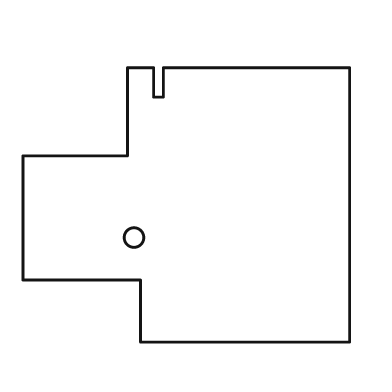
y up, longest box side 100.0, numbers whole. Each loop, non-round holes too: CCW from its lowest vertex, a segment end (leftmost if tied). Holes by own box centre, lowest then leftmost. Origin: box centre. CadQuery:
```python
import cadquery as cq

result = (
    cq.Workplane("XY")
    .moveTo(-14.0, -42.0)
    .lineTo(50.0, -42.0)
    .lineTo(50.0, 42.0)
    .lineTo(-7.0, 42.0)
    .lineTo(-7.0, 33.0)
    .lineTo(-10.0, 33.0)
    .lineTo(-10.0, 42.0)
    .lineTo(-18.0, 42.0)
    .lineTo(-18.0, 15.0)
    .lineTo(-50.0, 15.0)
    .lineTo(-50.0, -23.0)
    .lineTo(-14.0, -23.0)
    .close()
    .moveTo(-16.0, -10.0)
    .circle(3.0)
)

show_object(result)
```